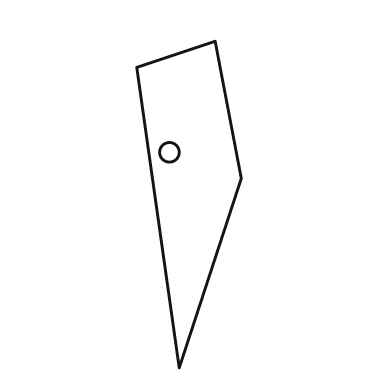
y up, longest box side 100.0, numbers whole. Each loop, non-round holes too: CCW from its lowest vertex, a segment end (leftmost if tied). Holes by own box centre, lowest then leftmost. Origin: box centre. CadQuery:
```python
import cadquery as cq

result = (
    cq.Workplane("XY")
    .moveTo(-3.0, -50.0)
    .lineTo(16.0, 8.0)
    .lineTo(8.0, 50.0)
    .lineTo(-16.0, 42.0)
    .close()
    .moveTo(-6.0, 16.0)
    .circle(3.0)
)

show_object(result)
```